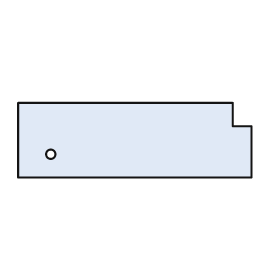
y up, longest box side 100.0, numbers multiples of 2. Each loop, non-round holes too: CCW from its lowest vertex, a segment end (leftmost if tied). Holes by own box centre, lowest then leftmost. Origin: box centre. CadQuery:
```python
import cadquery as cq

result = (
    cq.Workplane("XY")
    .moveTo(-50.0, -16.0)
    .lineTo(50.0, -16.0)
    .lineTo(50.0, 6.0)
    .lineTo(42.0, 6.0)
    .lineTo(42.0, 16.0)
    .lineTo(-50.0, 16.0)
    .close()
    .moveTo(-36.0, -6.0)
    .circle(2.0)
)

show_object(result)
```